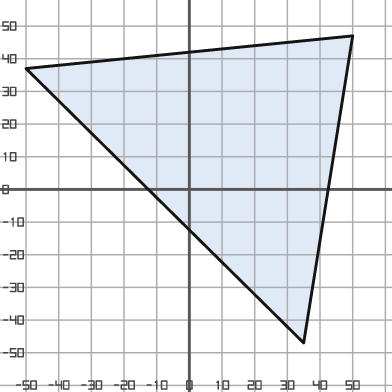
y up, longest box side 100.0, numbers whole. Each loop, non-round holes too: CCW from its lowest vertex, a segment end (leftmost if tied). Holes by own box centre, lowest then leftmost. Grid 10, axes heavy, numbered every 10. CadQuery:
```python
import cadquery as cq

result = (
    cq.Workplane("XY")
    .moveTo(35.0, -47.0)
    .lineTo(50.0, 47.0)
    .lineTo(-50.0, 37.0)
    .close()
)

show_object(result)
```